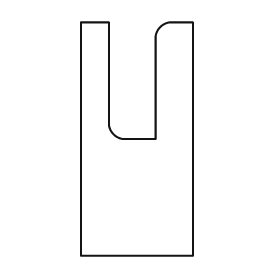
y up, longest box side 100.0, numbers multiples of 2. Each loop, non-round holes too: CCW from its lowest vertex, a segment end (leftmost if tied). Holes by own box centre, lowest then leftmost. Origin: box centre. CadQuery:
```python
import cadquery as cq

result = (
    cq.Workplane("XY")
    .moveTo(-24.0, -50.0)
    .lineTo(24.0, -50.0)
    .lineTo(24.0, 50.0)
    .lineTo(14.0, 50.0)
    .threePointArc((10.0, 48.0), (8.0, 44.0))
    .lineTo(8.0, 0.0)
    .lineTo(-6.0, 0.0)
    .threePointArc((-10.0, 2.0), (-12.0, 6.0))
    .lineTo(-12.0, 50.0)
    .lineTo(-24.0, 50.0)
    .close()
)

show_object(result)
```